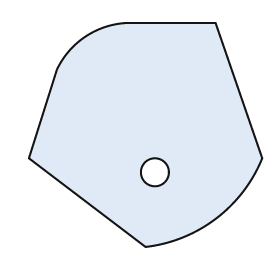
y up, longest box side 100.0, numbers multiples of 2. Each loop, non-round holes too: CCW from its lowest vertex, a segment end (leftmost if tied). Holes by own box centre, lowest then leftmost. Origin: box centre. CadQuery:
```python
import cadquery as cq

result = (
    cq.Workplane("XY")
    .moveTo(0.0, -48.0)
    .threePointArc((30.0, -36.0), (50.0, -10.0))
    .lineTo(30.0, 48.0)
    .lineTo(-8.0, 48.0)
    .threePointArc((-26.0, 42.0), (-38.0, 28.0))
    .lineTo(-50.0, -10.0)
    .close()
    .moveTo(4.0, -16.0)
    .circle(6.0)
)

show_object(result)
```